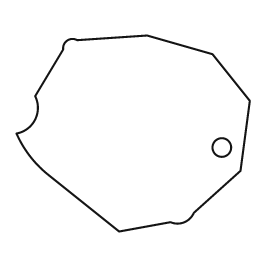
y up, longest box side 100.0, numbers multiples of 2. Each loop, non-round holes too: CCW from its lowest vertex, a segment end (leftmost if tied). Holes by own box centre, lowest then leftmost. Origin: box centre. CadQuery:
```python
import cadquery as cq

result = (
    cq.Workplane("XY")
    .moveTo(-6.0, -42.0)
    .lineTo(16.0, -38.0)
    .threePointArc((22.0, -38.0), (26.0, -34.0))
    .lineTo(46.0, -16.0)
    .lineTo(50.0, 14.0)
    .lineTo(34.0, 34.0)
    .lineTo(6.0, 42.0)
    .lineTo(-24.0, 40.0)
    .threePointArc((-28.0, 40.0), (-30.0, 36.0))
    .lineTo(-42.0, 16.0)
    .threePointArc((-42.0, 6.0), (-50.0, 0.0))
    .threePointArc((-44.0, -10.0), (-36.0, -18.0))
    .close()
    .moveTo(38.0, -6.0)
    .circle(4.0)
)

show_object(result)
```